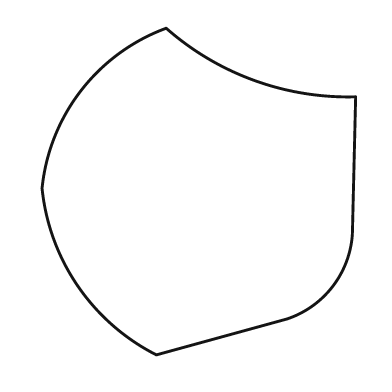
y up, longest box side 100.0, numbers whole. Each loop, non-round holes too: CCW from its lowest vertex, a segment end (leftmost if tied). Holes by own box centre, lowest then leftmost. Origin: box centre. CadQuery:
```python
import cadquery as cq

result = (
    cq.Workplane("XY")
    .moveTo(-13.0, -50.0)
    .lineTo(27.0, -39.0)
    .threePointArc((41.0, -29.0), (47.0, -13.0))
    .lineTo(48.0, 29.0)
    .threePointArc((17.0, 34.0), (-10.0, 50.0))
    .threePointArc((-36.0, 31.0), (-48.0, 1.0))
    .threePointArc((-37.0, -29.0), (-13.0, -50.0))
    .close()
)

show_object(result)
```